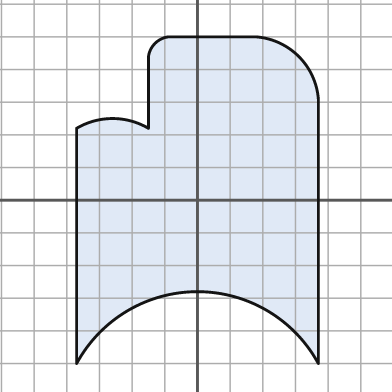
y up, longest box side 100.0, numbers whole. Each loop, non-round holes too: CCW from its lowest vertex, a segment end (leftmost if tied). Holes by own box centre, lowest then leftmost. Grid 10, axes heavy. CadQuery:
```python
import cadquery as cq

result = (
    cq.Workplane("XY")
    .moveTo(-37.0, -50.0)
    .threePointArc((0.0, -28.0), (37.0, -50.0))
    .lineTo(37.0, 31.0)
    .threePointArc((31.0, 44.0), (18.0, 50.0))
    .lineTo(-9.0, 50.0)
    .threePointArc((-13.0, 48.0), (-15.0, 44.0))
    .lineTo(-15.0, 22.0)
    .threePointArc((-26.0, 25.0), (-37.0, 22.0))
    .close()
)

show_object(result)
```